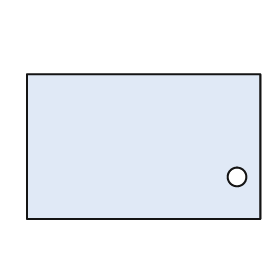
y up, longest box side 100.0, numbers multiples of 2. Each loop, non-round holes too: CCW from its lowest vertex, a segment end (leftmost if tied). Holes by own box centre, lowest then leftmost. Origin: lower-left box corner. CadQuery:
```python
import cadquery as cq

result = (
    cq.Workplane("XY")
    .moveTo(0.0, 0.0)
    .lineTo(100.0, 0.0)
    .lineTo(100.0, 62.0)
    .lineTo(0.0, 62.0)
    .close()
    .moveTo(90.0, 18.0)
    .circle(4.0)
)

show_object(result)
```